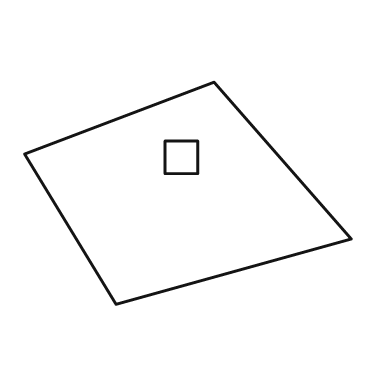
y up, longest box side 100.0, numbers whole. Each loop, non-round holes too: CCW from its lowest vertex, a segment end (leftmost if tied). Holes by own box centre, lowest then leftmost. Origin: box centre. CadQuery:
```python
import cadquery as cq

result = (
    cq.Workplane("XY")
    .moveTo(-22.0, -34.0)
    .lineTo(50.0, -14.0)
    .lineTo(8.0, 34.0)
    .lineTo(-50.0, 12.0)
    .close()
    .moveTo(-7.0, 6.0)
    .lineTo(3.0, 6.0)
    .lineTo(3.0, 16.0)
    .lineTo(-7.0, 16.0)
    .close()
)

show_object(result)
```